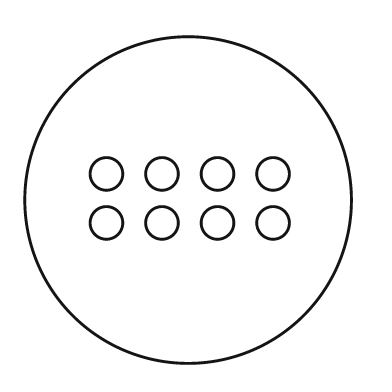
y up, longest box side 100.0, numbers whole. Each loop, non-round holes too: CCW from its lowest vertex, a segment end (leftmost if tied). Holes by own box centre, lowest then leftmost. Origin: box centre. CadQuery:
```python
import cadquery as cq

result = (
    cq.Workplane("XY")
    .moveTo(0.0, 0.0)
    .circle(50.0)
    .moveTo(-25.0, -7.0)
    .circle(5.0)
    .moveTo(-8.0, -7.0)
    .circle(5.0)
    .moveTo(9.0, -7.0)
    .circle(5.0)
    .moveTo(26.0, -7.0)
    .circle(5.0)
    .moveTo(-25.0, 8.0)
    .circle(5.0)
    .moveTo(-8.0, 8.0)
    .circle(5.0)
    .moveTo(9.0, 8.0)
    .circle(5.0)
    .moveTo(26.0, 8.0)
    .circle(5.0)
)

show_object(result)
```